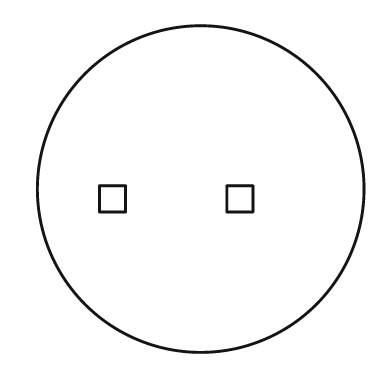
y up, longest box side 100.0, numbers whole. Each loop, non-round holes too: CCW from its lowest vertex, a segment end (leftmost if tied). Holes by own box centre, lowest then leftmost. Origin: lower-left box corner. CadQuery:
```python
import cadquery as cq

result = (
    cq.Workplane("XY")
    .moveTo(50.0, 50.0)
    .circle(50.0)
    .moveTo(19.0, 43.0)
    .lineTo(27.0, 43.0)
    .lineTo(27.0, 51.0)
    .lineTo(19.0, 51.0)
    .close()
    .moveTo(58.0, 43.0)
    .lineTo(66.0, 43.0)
    .lineTo(66.0, 51.0)
    .lineTo(58.0, 51.0)
    .close()
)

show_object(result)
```